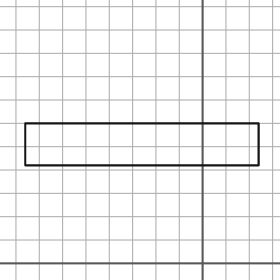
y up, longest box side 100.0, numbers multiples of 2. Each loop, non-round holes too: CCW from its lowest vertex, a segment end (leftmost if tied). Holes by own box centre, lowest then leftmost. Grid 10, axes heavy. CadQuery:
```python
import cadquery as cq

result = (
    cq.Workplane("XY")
    .moveTo(-76.0, 42.0)
    .lineTo(24.0, 42.0)
    .lineTo(24.0, 60.0)
    .lineTo(-76.0, 60.0)
    .close()
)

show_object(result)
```